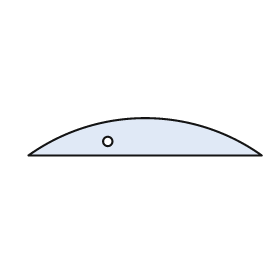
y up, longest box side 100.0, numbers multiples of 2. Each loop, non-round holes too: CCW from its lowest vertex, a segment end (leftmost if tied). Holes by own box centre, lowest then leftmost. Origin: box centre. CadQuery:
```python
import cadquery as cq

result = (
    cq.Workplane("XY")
    .moveTo(-50.0, -8.0)
    .lineTo(50.0, -8.0)
    .threePointArc((0.0, 8.0), (-50.0, -8.0))
    .close()
    .moveTo(-16.0, -2.0)
    .circle(2.0)
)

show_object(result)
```